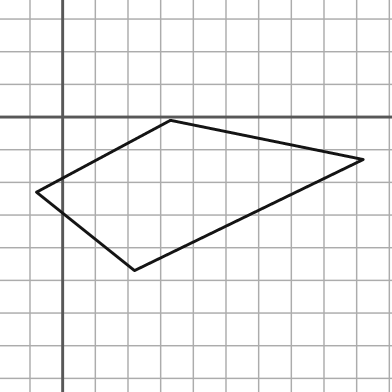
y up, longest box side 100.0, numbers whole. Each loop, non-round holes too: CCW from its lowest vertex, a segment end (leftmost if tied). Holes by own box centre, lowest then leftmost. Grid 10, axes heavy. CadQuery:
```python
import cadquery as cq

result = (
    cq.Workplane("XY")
    .moveTo(22.0, -47.0)
    .lineTo(92.0, -13.0)
    .lineTo(33.0, -1.0)
    .lineTo(-8.0, -23.0)
    .close()
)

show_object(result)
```